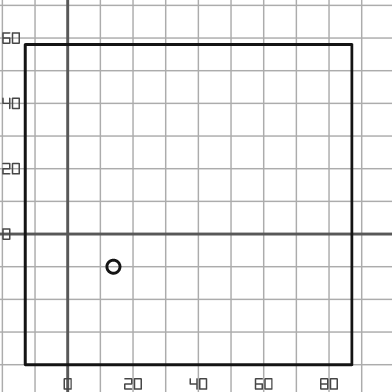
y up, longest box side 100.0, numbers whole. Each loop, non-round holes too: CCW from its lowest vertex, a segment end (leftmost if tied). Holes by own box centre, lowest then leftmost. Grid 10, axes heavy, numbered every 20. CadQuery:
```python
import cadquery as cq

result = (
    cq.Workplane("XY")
    .moveTo(-13.0, -40.0)
    .lineTo(87.0, -40.0)
    .lineTo(87.0, 58.0)
    .lineTo(-13.0, 58.0)
    .close()
    .moveTo(14.0, -10.0)
    .circle(2.0)
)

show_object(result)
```